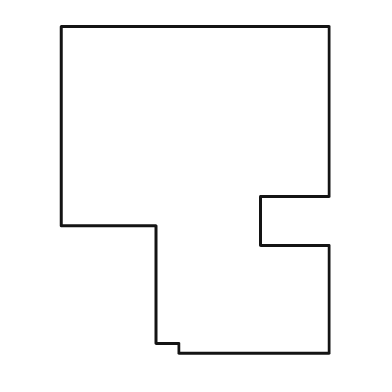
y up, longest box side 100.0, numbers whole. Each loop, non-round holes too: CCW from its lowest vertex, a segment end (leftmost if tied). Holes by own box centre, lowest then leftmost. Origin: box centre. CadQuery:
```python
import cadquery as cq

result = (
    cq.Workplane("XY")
    .moveTo(-5.0, -50.0)
    .lineTo(41.0, -50.0)
    .lineTo(41.0, -17.0)
    .lineTo(20.0, -17.0)
    .lineTo(20.0, -2.0)
    .lineTo(41.0, -2.0)
    .lineTo(41.0, 50.0)
    .lineTo(-41.0, 50.0)
    .lineTo(-41.0, -11.0)
    .lineTo(-12.0, -11.0)
    .lineTo(-12.0, -47.0)
    .lineTo(-5.0, -47.0)
    .close()
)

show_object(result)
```